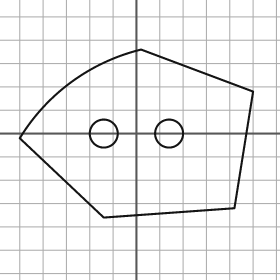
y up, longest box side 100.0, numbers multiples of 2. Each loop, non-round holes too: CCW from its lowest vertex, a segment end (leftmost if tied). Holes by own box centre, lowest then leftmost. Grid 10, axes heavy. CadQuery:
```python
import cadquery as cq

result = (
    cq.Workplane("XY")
    .moveTo(-14.0, -36.0)
    .lineTo(42.0, -32.0)
    .lineTo(50.0, 18.0)
    .lineTo(2.0, 36.0)
    .threePointArc((-28.0, 22.0), (-50.0, -2.0))
    .close()
    .moveTo(-14.0, 0.0)
    .circle(6.0)
    .moveTo(14.0, 0.0)
    .circle(6.0)
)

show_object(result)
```